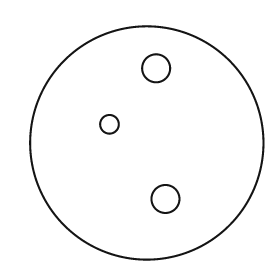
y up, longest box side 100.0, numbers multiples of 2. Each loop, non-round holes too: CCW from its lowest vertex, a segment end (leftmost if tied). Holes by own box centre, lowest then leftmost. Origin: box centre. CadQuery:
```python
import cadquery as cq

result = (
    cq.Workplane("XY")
    .moveTo(0.0, 0.0)
    .circle(50.0)
    .moveTo(8.0, -24.0)
    .circle(6.0)
    .moveTo(-16.0, 8.0)
    .circle(4.0)
    .moveTo(4.0, 32.0)
    .circle(6.0)
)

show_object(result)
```